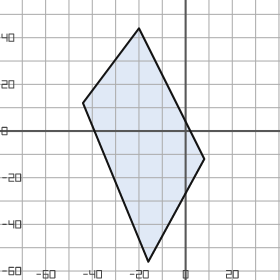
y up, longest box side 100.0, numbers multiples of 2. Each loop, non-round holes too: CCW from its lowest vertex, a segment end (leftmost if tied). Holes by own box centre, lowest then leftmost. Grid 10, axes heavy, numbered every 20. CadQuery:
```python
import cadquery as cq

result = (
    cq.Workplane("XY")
    .moveTo(-16.0, -56.0)
    .lineTo(8.0, -12.0)
    .lineTo(-20.0, 44.0)
    .lineTo(-44.0, 12.0)
    .close()
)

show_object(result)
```